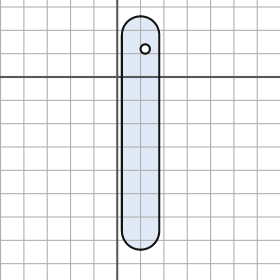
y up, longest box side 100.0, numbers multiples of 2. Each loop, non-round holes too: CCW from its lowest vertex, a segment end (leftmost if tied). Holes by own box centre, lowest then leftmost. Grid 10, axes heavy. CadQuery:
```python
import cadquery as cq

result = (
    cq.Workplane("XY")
    .moveTo(2.0, -66.0)
    .threePointArc((10.0, -74.0), (18.0, -66.0))
    .lineTo(18.0, 18.0)
    .threePointArc((10.0, 26.0), (2.0, 18.0))
    .close()
    .moveTo(12.0, 12.0)
    .circle(2.0)
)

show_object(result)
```